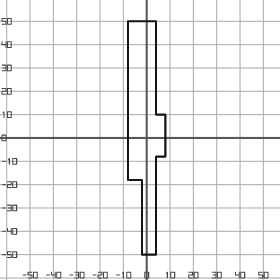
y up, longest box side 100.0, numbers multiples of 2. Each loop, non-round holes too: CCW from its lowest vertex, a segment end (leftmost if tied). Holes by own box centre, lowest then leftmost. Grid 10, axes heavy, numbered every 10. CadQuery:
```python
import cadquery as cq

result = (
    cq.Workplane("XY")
    .moveTo(-2.0, -50.0)
    .lineTo(4.0, -50.0)
    .lineTo(4.0, -8.0)
    .lineTo(8.0, -8.0)
    .lineTo(8.0, 10.0)
    .lineTo(4.0, 10.0)
    .lineTo(4.0, 50.0)
    .lineTo(-8.0, 50.0)
    .lineTo(-8.0, -18.0)
    .lineTo(-2.0, -18.0)
    .close()
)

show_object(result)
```